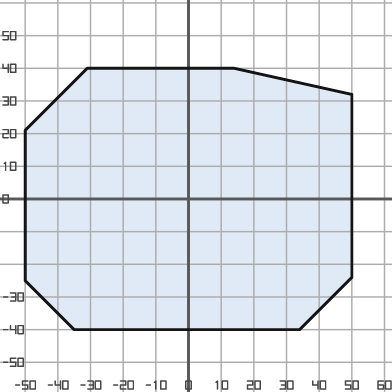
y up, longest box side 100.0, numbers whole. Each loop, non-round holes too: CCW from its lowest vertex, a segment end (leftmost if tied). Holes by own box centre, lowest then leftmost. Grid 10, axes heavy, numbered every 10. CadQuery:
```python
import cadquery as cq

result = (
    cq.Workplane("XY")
    .moveTo(-35.0, -40.0)
    .lineTo(34.0, -40.0)
    .lineTo(50.0, -24.0)
    .lineTo(50.0, 32.0)
    .lineTo(14.0, 40.0)
    .lineTo(-31.0, 40.0)
    .lineTo(-50.0, 21.0)
    .lineTo(-50.0, -25.0)
    .close()
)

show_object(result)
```